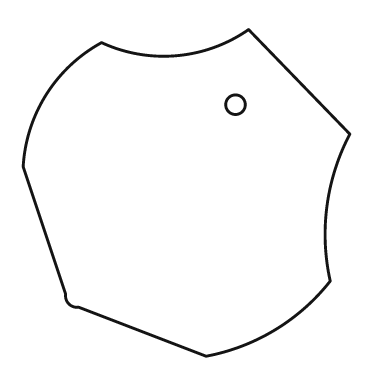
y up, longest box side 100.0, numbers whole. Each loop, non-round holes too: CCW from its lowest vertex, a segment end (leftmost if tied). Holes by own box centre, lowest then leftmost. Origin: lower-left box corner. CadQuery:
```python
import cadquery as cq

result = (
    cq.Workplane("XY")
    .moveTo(56.0, 0.0)
    .threePointArc((77.0, 8.0), (94.0, 23.0))
    .threePointArc((93.0, 46.0), (100.0, 68.0))
    .lineTo(69.0, 100.0)
    .threePointArc((47.0, 92.0), (24.0, 96.0))
    .threePointArc((7.0, 80.0), (0.0, 58.0))
    .lineTo(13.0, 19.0)
    .threePointArc((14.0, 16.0), (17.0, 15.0))
    .close()
    .moveTo(65.0, 77.0)
    .circle(3.0)
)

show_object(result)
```